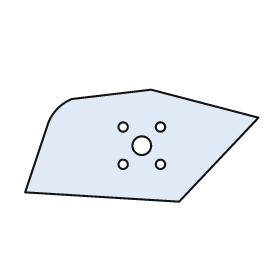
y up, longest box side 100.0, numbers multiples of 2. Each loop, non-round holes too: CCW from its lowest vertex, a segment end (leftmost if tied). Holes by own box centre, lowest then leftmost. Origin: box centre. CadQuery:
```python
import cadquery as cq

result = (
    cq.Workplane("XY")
    .moveTo(16.0, -24.0)
    .lineTo(50.0, 12.0)
    .lineTo(4.0, 24.0)
    .lineTo(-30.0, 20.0)
    .threePointArc((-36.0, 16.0), (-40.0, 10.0))
    .lineTo(-50.0, -20.0)
    .close()
    .moveTo(-8.0, -8.0)
    .circle(2.0)
    .moveTo(8.0, -8.0)
    .circle(2.0)
    .moveTo(0.0, 0.0)
    .circle(4.0)
    .moveTo(-8.0, 8.0)
    .circle(2.0)
    .moveTo(8.0, 8.0)
    .circle(2.0)
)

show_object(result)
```